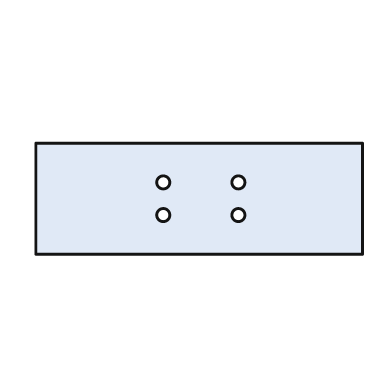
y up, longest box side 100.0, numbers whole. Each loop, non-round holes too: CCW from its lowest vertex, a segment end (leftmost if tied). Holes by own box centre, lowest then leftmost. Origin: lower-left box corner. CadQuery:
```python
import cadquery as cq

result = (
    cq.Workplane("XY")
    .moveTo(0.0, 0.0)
    .lineTo(100.0, 0.0)
    .lineTo(100.0, 34.0)
    .lineTo(0.0, 34.0)
    .close()
    .moveTo(39.0, 12.0)
    .circle(2.0)
    .moveTo(62.0, 12.0)
    .circle(2.0)
    .moveTo(39.0, 22.0)
    .circle(2.0)
    .moveTo(62.0, 22.0)
    .circle(2.0)
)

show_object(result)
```